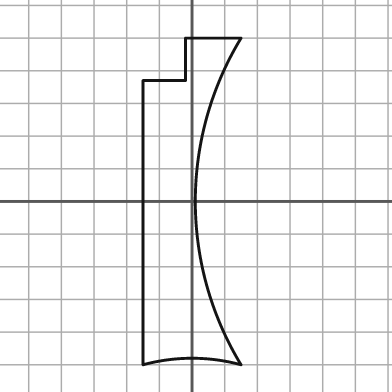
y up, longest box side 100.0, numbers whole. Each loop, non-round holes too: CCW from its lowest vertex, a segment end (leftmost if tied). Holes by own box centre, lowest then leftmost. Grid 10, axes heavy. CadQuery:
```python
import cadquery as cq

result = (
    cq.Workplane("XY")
    .moveTo(-15.0, -50.0)
    .threePointArc((0.0, -48.0), (15.0, -50.0))
    .threePointArc((1.0, 0.0), (15.0, 50.0))
    .lineTo(-2.0, 50.0)
    .lineTo(-2.0, 37.0)
    .lineTo(-15.0, 37.0)
    .close()
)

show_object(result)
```